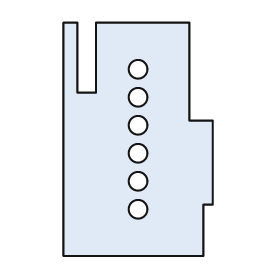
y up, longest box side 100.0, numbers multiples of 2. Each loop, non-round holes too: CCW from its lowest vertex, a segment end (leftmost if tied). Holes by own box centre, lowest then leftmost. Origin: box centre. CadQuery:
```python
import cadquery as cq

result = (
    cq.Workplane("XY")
    .moveTo(-32.0, -50.0)
    .lineTo(28.0, -50.0)
    .lineTo(28.0, -28.0)
    .lineTo(32.0, -28.0)
    .lineTo(32.0, 8.0)
    .lineTo(22.0, 8.0)
    .lineTo(22.0, 50.0)
    .lineTo(-18.0, 50.0)
    .lineTo(-18.0, 20.0)
    .lineTo(-26.0, 20.0)
    .lineTo(-26.0, 50.0)
    .lineTo(-32.0, 50.0)
    .close()
    .moveTo(0.0, -30.0)
    .circle(4.0)
    .moveTo(0.0, -18.0)
    .circle(4.0)
    .moveTo(0.0, -6.0)
    .circle(4.0)
    .moveTo(0.0, 6.0)
    .circle(4.0)
    .moveTo(0.0, 18.0)
    .circle(4.0)
    .moveTo(0.0, 30.0)
    .circle(4.0)
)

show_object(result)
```